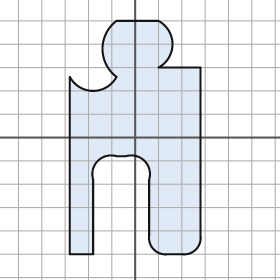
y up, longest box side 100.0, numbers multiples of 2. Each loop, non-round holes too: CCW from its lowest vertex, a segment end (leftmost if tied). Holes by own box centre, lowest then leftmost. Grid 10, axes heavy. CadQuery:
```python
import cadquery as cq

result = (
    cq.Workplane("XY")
    .moveTo(-28.0, -50.0)
    .lineTo(-18.0, -50.0)
    .lineTo(-18.0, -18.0)
    .threePointArc((-16.0, -10.0), (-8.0, -8.0))
    .lineTo(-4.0, -8.0)
    .threePointArc((4.0, -10.0), (6.0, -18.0))
    .lineTo(6.0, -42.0)
    .threePointArc((8.0, -48.0), (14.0, -50.0))
    .lineTo(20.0, -50.0)
    .threePointArc((26.0, -48.0), (28.0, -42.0))
    .lineTo(28.0, 30.0)
    .lineTo(10.0, 30.0)
    .threePointArc((16.0, 40.0), (10.0, 50.0))
    .lineTo(-8.0, 50.0)
    .threePointArc((-14.0, 38.0), (-8.0, 26.0))
    .threePointArc((-18.0, 20.0), (-28.0, 26.0))
    .close()
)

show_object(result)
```